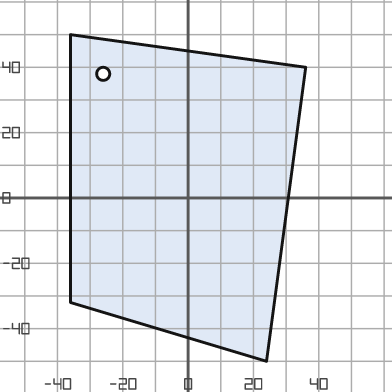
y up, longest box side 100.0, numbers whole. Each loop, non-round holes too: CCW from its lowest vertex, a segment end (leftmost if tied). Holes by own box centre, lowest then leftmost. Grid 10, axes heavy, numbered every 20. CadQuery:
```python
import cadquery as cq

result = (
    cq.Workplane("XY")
    .moveTo(24.0, -50.0)
    .lineTo(36.0, 40.0)
    .lineTo(-36.0, 50.0)
    .lineTo(-36.0, -32.0)
    .close()
    .moveTo(-26.0, 38.0)
    .circle(2.0)
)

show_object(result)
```